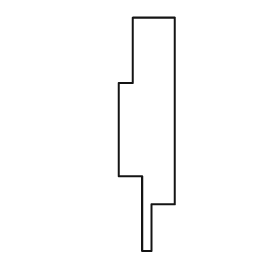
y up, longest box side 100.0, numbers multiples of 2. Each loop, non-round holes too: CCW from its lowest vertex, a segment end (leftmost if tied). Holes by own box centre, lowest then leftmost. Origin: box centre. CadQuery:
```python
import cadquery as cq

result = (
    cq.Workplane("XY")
    .moveTo(-2.0, -50.0)
    .lineTo(2.0, -50.0)
    .lineTo(2.0, -30.0)
    .lineTo(12.0, -30.0)
    .lineTo(12.0, 50.0)
    .lineTo(-6.0, 50.0)
    .lineTo(-6.0, 22.0)
    .lineTo(-12.0, 22.0)
    .lineTo(-12.0, -18.0)
    .lineTo(-2.0, -18.0)
    .close()
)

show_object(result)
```